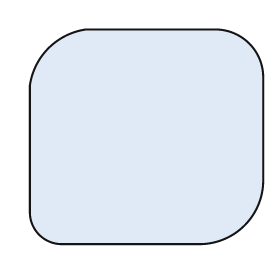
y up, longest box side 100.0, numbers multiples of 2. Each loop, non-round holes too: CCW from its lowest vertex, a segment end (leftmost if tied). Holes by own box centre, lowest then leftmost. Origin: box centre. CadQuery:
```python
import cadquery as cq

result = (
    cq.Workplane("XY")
    .moveTo(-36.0, -46.0)
    .lineTo(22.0, -46.0)
    .threePointArc((42.0, -38.0), (50.0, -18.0))
    .lineTo(50.0, 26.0)
    .threePointArc((44.0, 40.0), (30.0, 46.0))
    .lineTo(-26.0, 46.0)
    .threePointArc((-42.0, 38.0), (-50.0, 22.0))
    .lineTo(-50.0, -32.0)
    .threePointArc((-46.0, -42.0), (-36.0, -46.0))
    .close()
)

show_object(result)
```